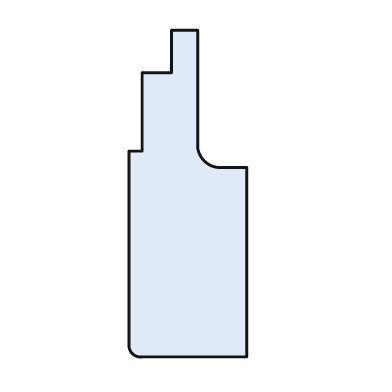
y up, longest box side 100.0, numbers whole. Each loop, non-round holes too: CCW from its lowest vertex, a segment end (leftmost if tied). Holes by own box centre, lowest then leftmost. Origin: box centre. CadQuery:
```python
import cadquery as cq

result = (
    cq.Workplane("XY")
    .moveTo(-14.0, -50.0)
    .lineTo(18.0, -50.0)
    .lineTo(18.0, 8.0)
    .lineTo(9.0, 8.0)
    .threePointArc((5.0, 10.0), (3.0, 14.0))
    .lineTo(3.0, 50.0)
    .lineTo(-5.0, 50.0)
    .lineTo(-5.0, 37.0)
    .lineTo(-14.0, 37.0)
    .lineTo(-14.0, 13.0)
    .lineTo(-18.0, 13.0)
    .lineTo(-18.0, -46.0)
    .threePointArc((-17.0, -49.0), (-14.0, -50.0))
    .close()
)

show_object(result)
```